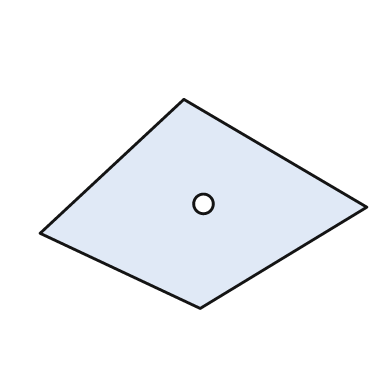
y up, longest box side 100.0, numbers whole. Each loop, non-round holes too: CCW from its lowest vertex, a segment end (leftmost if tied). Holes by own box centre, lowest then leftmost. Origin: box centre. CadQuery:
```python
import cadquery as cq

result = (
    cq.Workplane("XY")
    .moveTo(-1.0, -32.0)
    .lineTo(50.0, -1.0)
    .lineTo(-6.0, 32.0)
    .lineTo(-50.0, -9.0)
    .close()
    .moveTo(0.0, 0.0)
    .circle(3.0)
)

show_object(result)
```